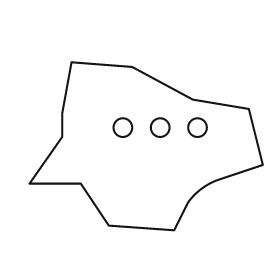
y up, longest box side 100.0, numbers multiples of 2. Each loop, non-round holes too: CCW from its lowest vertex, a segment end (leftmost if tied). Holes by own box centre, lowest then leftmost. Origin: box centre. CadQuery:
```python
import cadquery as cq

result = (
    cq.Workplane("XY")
    .moveTo(12.0, -36.0)
    .lineTo(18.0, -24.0)
    .threePointArc((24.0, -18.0), (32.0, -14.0))
    .lineTo(50.0, -8.0)
    .lineTo(44.0, 16.0)
    .lineTo(20.0, 20.0)
    .lineTo(-6.0, 34.0)
    .lineTo(-32.0, 36.0)
    .lineTo(-36.0, 14.0)
    .lineTo(-36.0, 4.0)
    .lineTo(-50.0, -16.0)
    .lineTo(-28.0, -16.0)
    .lineTo(-16.0, -34.0)
    .close()
    .moveTo(-10.0, 8.0)
    .circle(4.0)
    .moveTo(6.0, 8.0)
    .circle(4.0)
    .moveTo(22.0, 8.0)
    .circle(4.0)
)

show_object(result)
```